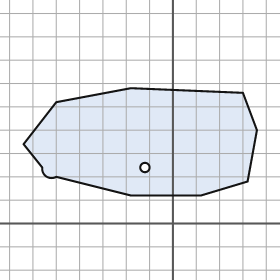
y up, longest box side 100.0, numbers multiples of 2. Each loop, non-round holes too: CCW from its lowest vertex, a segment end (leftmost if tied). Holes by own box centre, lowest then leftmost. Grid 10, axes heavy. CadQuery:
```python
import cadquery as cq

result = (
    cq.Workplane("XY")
    .moveTo(-18.0, 12.0)
    .lineTo(12.0, 12.0)
    .lineTo(32.0, 18.0)
    .lineTo(36.0, 40.0)
    .lineTo(30.0, 56.0)
    .lineTo(-18.0, 58.0)
    .lineTo(-50.0, 52.0)
    .lineTo(-64.0, 34.0)
    .lineTo(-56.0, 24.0)
    .threePointArc((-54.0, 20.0), (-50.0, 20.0))
    .close()
    .moveTo(-12.0, 24.0)
    .circle(2.0)
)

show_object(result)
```